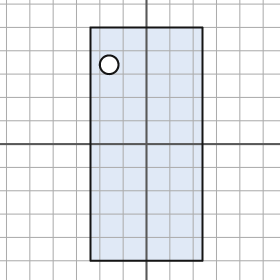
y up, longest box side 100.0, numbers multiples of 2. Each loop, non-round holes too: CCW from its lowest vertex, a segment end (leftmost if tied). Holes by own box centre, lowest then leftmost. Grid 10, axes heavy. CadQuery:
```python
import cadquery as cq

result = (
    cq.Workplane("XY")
    .moveTo(-24.0, -50.0)
    .lineTo(24.0, -50.0)
    .lineTo(24.0, 50.0)
    .lineTo(-24.0, 50.0)
    .close()
    .moveTo(-16.0, 34.0)
    .circle(4.0)
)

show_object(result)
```